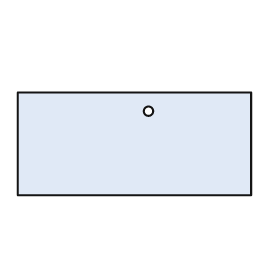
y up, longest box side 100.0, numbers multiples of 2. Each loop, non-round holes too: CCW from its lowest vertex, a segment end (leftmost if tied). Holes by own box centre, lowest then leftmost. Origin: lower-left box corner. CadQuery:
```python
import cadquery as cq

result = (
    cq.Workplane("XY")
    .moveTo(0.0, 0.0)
    .lineTo(100.0, 0.0)
    .lineTo(100.0, 44.0)
    .lineTo(0.0, 44.0)
    .close()
    .moveTo(56.0, 36.0)
    .circle(2.0)
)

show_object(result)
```